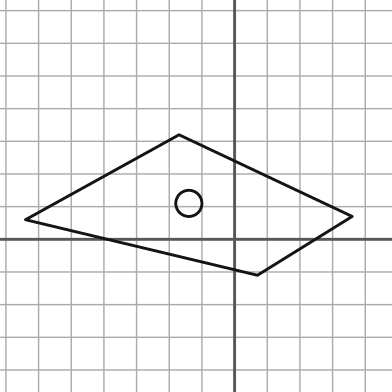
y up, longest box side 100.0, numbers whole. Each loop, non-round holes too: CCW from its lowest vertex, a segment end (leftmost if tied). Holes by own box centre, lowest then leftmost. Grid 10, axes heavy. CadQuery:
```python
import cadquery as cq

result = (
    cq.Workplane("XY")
    .moveTo(7.0, -11.0)
    .lineTo(36.0, 7.0)
    .lineTo(-17.0, 32.0)
    .lineTo(-64.0, 6.0)
    .close()
    .moveTo(-14.0, 11.0)
    .circle(4.0)
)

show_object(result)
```